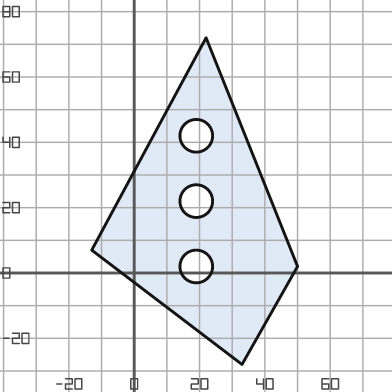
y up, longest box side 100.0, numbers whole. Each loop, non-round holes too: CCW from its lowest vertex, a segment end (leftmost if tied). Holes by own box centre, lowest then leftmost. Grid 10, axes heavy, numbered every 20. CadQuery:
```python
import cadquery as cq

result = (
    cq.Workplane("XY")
    .moveTo(33.0, -28.0)
    .lineTo(50.0, 2.0)
    .lineTo(22.0, 72.0)
    .lineTo(-13.0, 7.0)
    .close()
    .moveTo(19.0, 2.0)
    .circle(5.0)
    .moveTo(19.0, 22.0)
    .circle(5.0)
    .moveTo(19.0, 42.0)
    .circle(5.0)
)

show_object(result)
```